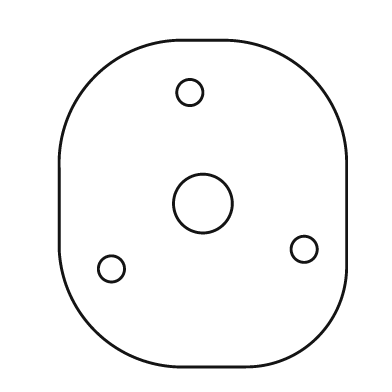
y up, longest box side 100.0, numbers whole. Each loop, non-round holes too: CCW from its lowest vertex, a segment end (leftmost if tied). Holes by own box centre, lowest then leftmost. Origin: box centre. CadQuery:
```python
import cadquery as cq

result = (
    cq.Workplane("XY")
    .moveTo(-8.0, -50.0)
    .lineTo(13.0, -50.0)
    .threePointArc((35.0, -41.0), (44.0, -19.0))
    .lineTo(44.0, 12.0)
    .threePointArc((33.0, 39.0), (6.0, 50.0))
    .lineTo(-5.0, 50.0)
    .threePointArc((-33.0, 39.0), (-44.0, 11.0))
    .lineTo(-44.0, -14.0)
    .threePointArc((-33.0, -39.0), (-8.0, -50.0))
    .close()
    .moveTo(-28.0, -20.0)
    .circle(4.0)
    .moveTo(31.0, -14.0)
    .circle(4.0)
    .moveTo(0.0, 0.0)
    .circle(9.0)
    .moveTo(-4.0, 34.0)
    .circle(4.0)
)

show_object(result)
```